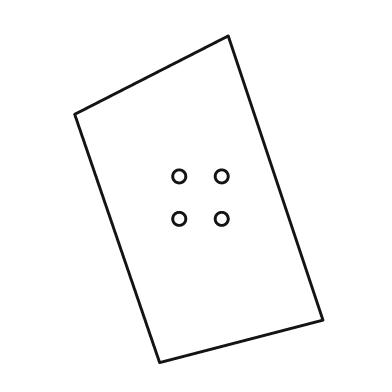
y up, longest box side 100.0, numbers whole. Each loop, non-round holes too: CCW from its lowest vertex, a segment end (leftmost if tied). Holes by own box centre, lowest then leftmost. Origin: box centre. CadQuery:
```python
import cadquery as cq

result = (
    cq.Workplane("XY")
    .moveTo(-12.0, -50.0)
    .lineTo(38.0, -37.0)
    .lineTo(9.0, 50.0)
    .lineTo(-38.0, 26.0)
    .close()
    .moveTo(-6.0, -6.0)
    .circle(2.0)
    .moveTo(7.0, -6.0)
    .circle(2.0)
    .moveTo(-6.0, 7.0)
    .circle(2.0)
    .moveTo(7.0, 7.0)
    .circle(2.0)
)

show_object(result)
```